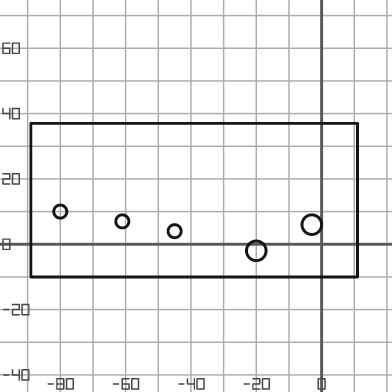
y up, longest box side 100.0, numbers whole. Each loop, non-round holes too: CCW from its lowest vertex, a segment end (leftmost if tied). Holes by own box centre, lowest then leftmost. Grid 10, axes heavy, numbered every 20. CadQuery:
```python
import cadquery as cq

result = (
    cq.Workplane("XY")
    .moveTo(-89.0, -10.0)
    .lineTo(11.0, -10.0)
    .lineTo(11.0, 37.0)
    .lineTo(-89.0, 37.0)
    .close()
    .moveTo(-20.0, -2.0)
    .circle(3.0)
    .moveTo(-45.0, 4.0)
    .circle(2.0)
    .moveTo(-3.0, 6.0)
    .circle(3.0)
    .moveTo(-61.0, 7.0)
    .circle(2.0)
    .moveTo(-80.0, 10.0)
    .circle(2.0)
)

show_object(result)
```